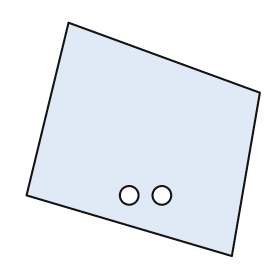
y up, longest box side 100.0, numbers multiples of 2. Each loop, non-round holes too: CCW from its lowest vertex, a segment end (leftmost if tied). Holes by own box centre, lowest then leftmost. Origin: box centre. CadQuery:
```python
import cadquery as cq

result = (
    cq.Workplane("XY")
    .moveTo(38.0, -50.0)
    .lineTo(50.0, 20.0)
    .lineTo(-32.0, 50.0)
    .lineTo(-50.0, -24.0)
    .close()
    .moveTo(-6.0, -24.0)
    .circle(4.0)
    .moveTo(8.0, -24.0)
    .circle(4.0)
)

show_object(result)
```